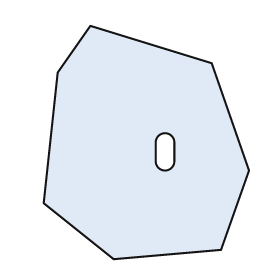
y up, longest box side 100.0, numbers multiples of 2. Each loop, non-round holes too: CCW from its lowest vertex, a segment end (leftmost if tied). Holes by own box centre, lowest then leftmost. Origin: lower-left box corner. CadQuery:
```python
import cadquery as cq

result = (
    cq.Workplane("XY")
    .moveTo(30.0, 0.0)
    .lineTo(76.0, 4.0)
    .lineTo(88.0, 38.0)
    .lineTo(72.0, 84.0)
    .lineTo(20.0, 100.0)
    .lineTo(6.0, 80.0)
    .lineTo(0.0, 24.0)
    .close()
    .moveTo(48.0, 42.0)
    .threePointArc((52.0, 38.0), (56.0, 42.0))
    .lineTo(56.0, 50.0)
    .threePointArc((52.0, 54.0), (48.0, 50.0))
    .close()
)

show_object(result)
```